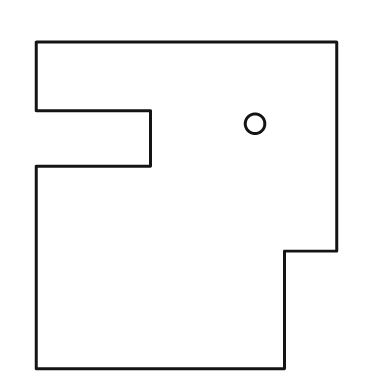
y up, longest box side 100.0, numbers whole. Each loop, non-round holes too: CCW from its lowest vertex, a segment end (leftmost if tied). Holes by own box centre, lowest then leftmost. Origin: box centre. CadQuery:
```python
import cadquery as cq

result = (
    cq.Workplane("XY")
    .moveTo(-46.0, -50.0)
    .lineTo(30.0, -50.0)
    .lineTo(30.0, -14.0)
    .lineTo(46.0, -14.0)
    .lineTo(46.0, 50.0)
    .lineTo(-46.0, 50.0)
    .lineTo(-46.0, 29.0)
    .lineTo(-11.0, 29.0)
    .lineTo(-11.0, 12.0)
    .lineTo(-46.0, 12.0)
    .close()
    .moveTo(21.0, 25.0)
    .circle(3.0)
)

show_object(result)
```